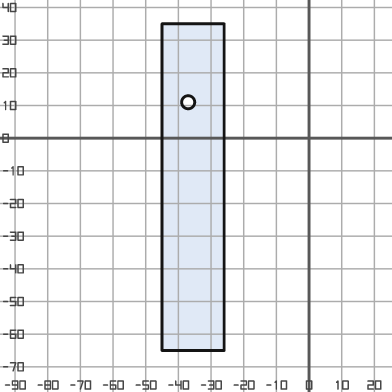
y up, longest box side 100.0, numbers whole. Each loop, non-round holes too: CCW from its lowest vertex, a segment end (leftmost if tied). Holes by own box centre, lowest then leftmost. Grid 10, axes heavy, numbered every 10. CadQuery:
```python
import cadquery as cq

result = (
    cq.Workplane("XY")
    .moveTo(-45.0, -65.0)
    .lineTo(-26.0, -65.0)
    .lineTo(-26.0, 35.0)
    .lineTo(-45.0, 35.0)
    .close()
    .moveTo(-37.0, 11.0)
    .circle(2.0)
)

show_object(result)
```